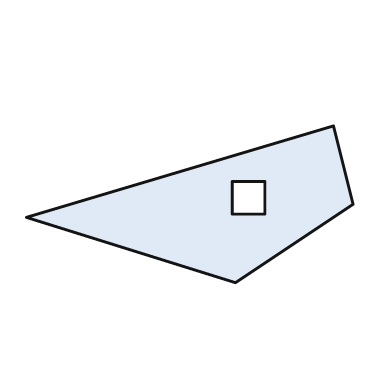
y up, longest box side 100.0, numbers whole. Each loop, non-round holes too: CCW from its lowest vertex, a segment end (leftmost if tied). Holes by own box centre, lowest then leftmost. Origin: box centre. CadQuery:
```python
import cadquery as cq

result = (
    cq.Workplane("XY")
    .moveTo(14.0, -24.0)
    .lineTo(50.0, 0.0)
    .lineTo(44.0, 24.0)
    .lineTo(-50.0, -4.0)
    .close()
    .moveTo(13.0, -3.0)
    .lineTo(23.0, -3.0)
    .lineTo(23.0, 7.0)
    .lineTo(13.0, 7.0)
    .close()
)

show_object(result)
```